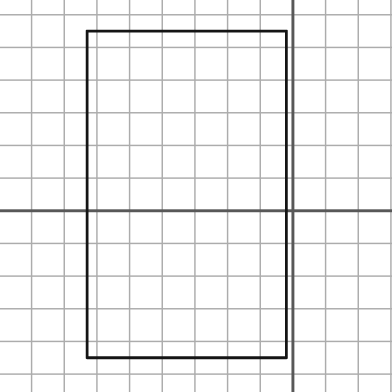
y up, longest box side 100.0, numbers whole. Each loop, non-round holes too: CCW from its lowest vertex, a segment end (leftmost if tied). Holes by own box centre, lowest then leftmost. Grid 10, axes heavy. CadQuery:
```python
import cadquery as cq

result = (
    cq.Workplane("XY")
    .moveTo(-63.0, -45.0)
    .lineTo(-2.0, -45.0)
    .lineTo(-2.0, 55.0)
    .lineTo(-63.0, 55.0)
    .close()
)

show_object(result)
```